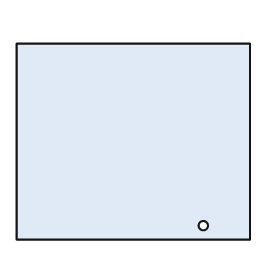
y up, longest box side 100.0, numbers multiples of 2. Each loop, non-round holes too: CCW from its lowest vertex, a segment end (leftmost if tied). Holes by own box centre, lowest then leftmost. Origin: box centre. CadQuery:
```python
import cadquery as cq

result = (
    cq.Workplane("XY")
    .moveTo(-50.0, -42.0)
    .lineTo(50.0, -42.0)
    .lineTo(50.0, 42.0)
    .lineTo(-50.0, 42.0)
    .close()
    .moveTo(30.0, -36.0)
    .circle(2.0)
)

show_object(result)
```